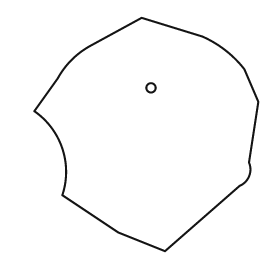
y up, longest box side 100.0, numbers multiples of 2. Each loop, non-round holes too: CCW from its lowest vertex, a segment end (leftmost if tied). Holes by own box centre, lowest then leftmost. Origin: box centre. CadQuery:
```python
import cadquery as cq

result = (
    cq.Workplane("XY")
    .moveTo(8.0, -50.0)
    .lineTo(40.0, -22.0)
    .threePointArc((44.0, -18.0), (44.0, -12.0))
    .lineTo(48.0, 14.0)
    .lineTo(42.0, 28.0)
    .threePointArc((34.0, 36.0), (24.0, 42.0))
    .lineTo(-2.0, 50.0)
    .lineTo(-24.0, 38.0)
    .threePointArc((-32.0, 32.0), (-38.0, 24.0))
    .lineTo(-48.0, 10.0)
    .threePointArc((-36.0, -6.0), (-36.0, -26.0))
    .lineTo(-12.0, -42.0)
    .close()
    .moveTo(2.0, 20.0)
    .circle(2.0)
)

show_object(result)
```